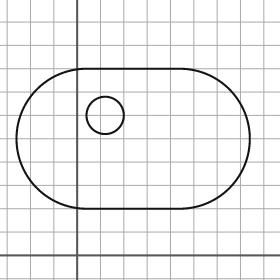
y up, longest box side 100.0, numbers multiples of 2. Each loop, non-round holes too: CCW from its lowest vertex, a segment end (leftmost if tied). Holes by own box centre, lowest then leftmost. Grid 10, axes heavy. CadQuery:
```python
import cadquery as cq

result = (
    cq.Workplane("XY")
    .moveTo(4.0, 20.0)
    .lineTo(44.0, 20.0)
    .threePointArc((74.0, 50.0), (44.0, 80.0))
    .lineTo(4.0, 80.0)
    .threePointArc((-26.0, 50.0), (4.0, 20.0))
    .close()
    .moveTo(12.0, 60.0)
    .circle(8.0)
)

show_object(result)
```